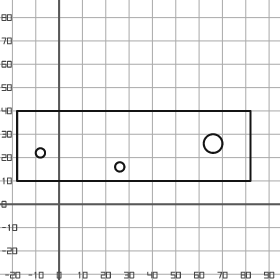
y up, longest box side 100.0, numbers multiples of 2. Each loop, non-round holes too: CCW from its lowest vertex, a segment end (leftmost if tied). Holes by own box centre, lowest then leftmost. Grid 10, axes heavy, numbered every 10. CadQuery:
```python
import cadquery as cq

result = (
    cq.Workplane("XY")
    .moveTo(-18.0, 10.0)
    .lineTo(82.0, 10.0)
    .lineTo(82.0, 40.0)
    .lineTo(-18.0, 40.0)
    .close()
    .moveTo(26.0, 16.0)
    .circle(2.0)
    .moveTo(-8.0, 22.0)
    .circle(2.0)
    .moveTo(66.0, 26.0)
    .circle(4.0)
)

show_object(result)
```